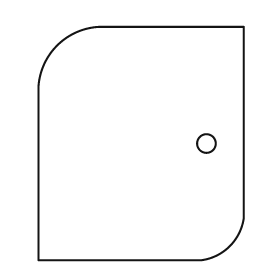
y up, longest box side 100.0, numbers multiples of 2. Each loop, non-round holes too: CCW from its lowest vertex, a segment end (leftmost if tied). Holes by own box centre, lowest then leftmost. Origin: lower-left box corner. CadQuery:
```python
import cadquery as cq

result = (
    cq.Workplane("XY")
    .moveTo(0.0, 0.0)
    .lineTo(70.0, 0.0)
    .threePointArc((82.0, 6.0), (88.0, 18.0))
    .lineTo(88.0, 100.0)
    .lineTo(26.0, 100.0)
    .threePointArc((8.0, 92.0), (0.0, 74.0))
    .close()
    .moveTo(72.0, 50.0)
    .circle(4.0)
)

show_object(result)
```